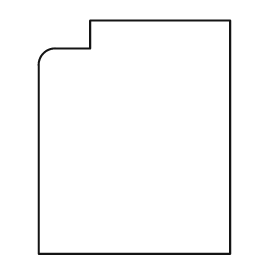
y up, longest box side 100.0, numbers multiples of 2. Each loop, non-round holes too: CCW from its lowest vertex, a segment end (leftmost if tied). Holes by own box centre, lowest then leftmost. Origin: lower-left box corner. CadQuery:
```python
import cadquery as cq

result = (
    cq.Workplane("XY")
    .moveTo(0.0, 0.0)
    .lineTo(82.0, 0.0)
    .lineTo(82.0, 100.0)
    .lineTo(22.0, 100.0)
    .lineTo(22.0, 88.0)
    .lineTo(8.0, 88.0)
    .threePointArc((2.0, 86.0), (0.0, 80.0))
    .close()
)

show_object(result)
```